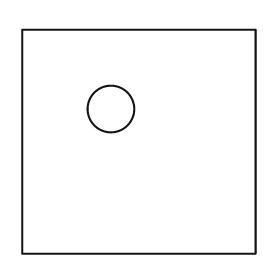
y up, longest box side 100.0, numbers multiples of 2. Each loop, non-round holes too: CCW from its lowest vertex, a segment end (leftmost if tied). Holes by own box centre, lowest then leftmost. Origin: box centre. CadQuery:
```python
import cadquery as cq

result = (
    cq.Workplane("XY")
    .moveTo(-50.0, -48.0)
    .lineTo(50.0, -48.0)
    .lineTo(50.0, 48.0)
    .lineTo(-50.0, 48.0)
    .close()
    .moveTo(-12.0, 14.0)
    .circle(10.0)
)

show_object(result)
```